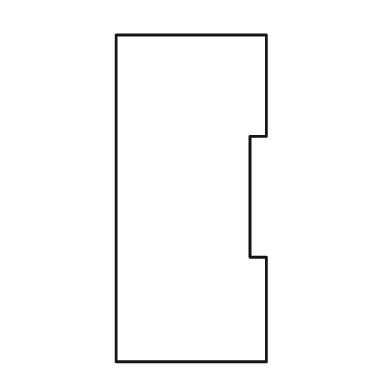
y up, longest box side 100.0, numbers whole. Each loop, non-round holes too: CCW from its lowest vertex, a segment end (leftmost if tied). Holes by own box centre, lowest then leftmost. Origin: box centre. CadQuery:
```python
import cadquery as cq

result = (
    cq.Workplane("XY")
    .moveTo(-23.0, -50.0)
    .lineTo(23.0, -50.0)
    .lineTo(23.0, -18.0)
    .lineTo(18.0, -18.0)
    .lineTo(18.0, 19.0)
    .lineTo(23.0, 19.0)
    .lineTo(23.0, 50.0)
    .lineTo(-23.0, 50.0)
    .close()
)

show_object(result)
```